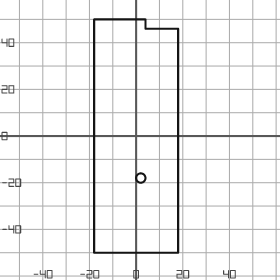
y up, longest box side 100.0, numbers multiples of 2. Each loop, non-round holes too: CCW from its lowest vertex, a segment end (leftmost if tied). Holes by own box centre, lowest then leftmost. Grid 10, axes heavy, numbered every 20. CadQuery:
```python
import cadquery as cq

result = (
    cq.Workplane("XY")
    .moveTo(-18.0, -50.0)
    .lineTo(18.0, -50.0)
    .lineTo(18.0, 46.0)
    .lineTo(4.0, 46.0)
    .lineTo(4.0, 50.0)
    .lineTo(-18.0, 50.0)
    .close()
    .moveTo(2.0, -18.0)
    .circle(2.0)
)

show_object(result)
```